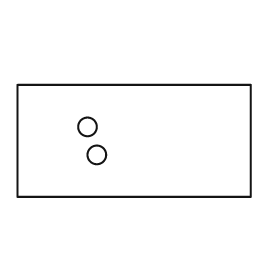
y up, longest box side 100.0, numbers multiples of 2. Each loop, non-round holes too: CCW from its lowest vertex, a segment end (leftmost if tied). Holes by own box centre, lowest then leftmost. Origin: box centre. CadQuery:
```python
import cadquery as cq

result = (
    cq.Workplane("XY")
    .moveTo(-50.0, -24.0)
    .lineTo(50.0, -24.0)
    .lineTo(50.0, 24.0)
    .lineTo(-50.0, 24.0)
    .close()
    .moveTo(-16.0, -6.0)
    .circle(4.0)
    .moveTo(-20.0, 6.0)
    .circle(4.0)
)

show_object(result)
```